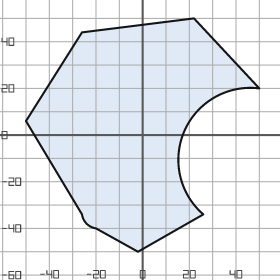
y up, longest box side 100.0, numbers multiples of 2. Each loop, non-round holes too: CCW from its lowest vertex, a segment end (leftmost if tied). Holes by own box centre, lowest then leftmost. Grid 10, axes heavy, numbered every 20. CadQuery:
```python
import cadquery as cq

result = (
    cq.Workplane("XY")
    .moveTo(-2.0, -50.0)
    .lineTo(26.0, -34.0)
    .threePointArc((18.0, 2.0), (50.0, 20.0))
    .lineTo(22.0, 50.0)
    .lineTo(-26.0, 44.0)
    .lineTo(-50.0, 6.0)
    .lineTo(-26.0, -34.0)
    .threePointArc((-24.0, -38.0), (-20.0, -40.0))
    .close()
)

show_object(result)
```